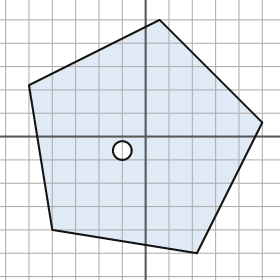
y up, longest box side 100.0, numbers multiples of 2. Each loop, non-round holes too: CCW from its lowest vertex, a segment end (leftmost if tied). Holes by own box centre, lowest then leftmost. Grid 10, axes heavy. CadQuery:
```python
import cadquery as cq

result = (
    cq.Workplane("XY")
    .moveTo(22.0, -50.0)
    .lineTo(50.0, 6.0)
    .lineTo(6.0, 50.0)
    .lineTo(-50.0, 22.0)
    .lineTo(-40.0, -40.0)
    .close()
    .moveTo(-10.0, -6.0)
    .circle(4.0)
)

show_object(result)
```